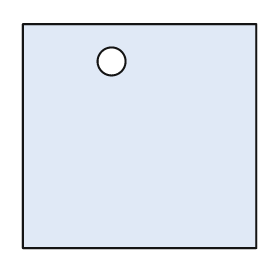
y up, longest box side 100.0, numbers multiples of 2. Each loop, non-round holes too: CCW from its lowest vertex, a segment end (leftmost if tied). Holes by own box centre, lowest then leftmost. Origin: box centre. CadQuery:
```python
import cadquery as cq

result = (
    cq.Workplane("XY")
    .moveTo(-50.0, -48.0)
    .lineTo(50.0, -48.0)
    .lineTo(50.0, 48.0)
    .lineTo(-50.0, 48.0)
    .close()
    .moveTo(-12.0, 32.0)
    .circle(6.0)
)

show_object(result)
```